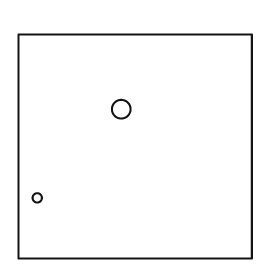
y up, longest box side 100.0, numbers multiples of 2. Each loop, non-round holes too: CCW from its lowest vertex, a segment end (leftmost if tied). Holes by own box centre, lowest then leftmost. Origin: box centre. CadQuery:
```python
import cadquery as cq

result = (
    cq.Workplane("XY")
    .moveTo(-50.0, -48.0)
    .lineTo(50.0, -48.0)
    .lineTo(50.0, 48.0)
    .lineTo(-50.0, 48.0)
    .close()
    .moveTo(-42.0, -22.0)
    .circle(2.0)
    .moveTo(-6.0, 16.0)
    .circle(4.0)
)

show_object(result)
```